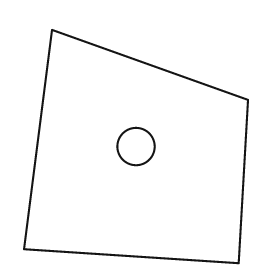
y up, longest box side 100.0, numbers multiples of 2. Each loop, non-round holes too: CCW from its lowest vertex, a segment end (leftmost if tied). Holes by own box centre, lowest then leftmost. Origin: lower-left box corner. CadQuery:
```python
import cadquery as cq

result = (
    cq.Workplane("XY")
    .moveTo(92.0, 0.0)
    .lineTo(96.0, 70.0)
    .lineTo(12.0, 100.0)
    .lineTo(0.0, 6.0)
    .close()
    .moveTo(48.0, 50.0)
    .circle(8.0)
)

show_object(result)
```